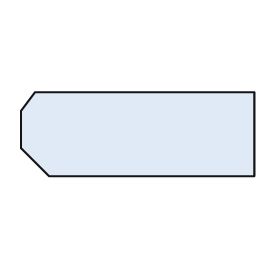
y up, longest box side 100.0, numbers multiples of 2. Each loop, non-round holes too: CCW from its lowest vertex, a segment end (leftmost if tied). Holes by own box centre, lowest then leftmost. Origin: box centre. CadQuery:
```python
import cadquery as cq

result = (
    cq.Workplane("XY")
    .moveTo(-38.0, -18.0)
    .lineTo(50.0, -18.0)
    .lineTo(50.0, 18.0)
    .lineTo(-44.0, 18.0)
    .lineTo(-50.0, 10.0)
    .lineTo(-50.0, -6.0)
    .close()
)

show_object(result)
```